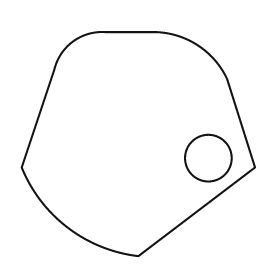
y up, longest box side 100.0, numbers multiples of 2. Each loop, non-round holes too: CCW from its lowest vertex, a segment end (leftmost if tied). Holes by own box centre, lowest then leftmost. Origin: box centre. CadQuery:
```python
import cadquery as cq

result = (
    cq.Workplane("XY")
    .moveTo(0.0, -48.0)
    .lineTo(50.0, -10.0)
    .lineTo(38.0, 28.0)
    .threePointArc((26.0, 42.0), (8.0, 48.0))
    .lineTo(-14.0, 48.0)
    .threePointArc((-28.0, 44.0), (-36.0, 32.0))
    .lineTo(-50.0, -10.0)
    .threePointArc((-30.0, -36.0), (0.0, -48.0))
    .close()
    .moveTo(30.0, -6.0)
    .circle(10.0)
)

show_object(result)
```